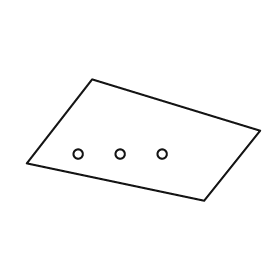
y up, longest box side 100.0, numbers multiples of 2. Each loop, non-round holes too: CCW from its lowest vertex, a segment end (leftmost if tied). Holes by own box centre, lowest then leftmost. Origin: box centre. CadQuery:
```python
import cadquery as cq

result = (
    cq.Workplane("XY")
    .moveTo(26.0, -26.0)
    .lineTo(50.0, 4.0)
    .lineTo(-22.0, 26.0)
    .lineTo(-50.0, -10.0)
    .close()
    .moveTo(-28.0, -6.0)
    .circle(2.0)
    .moveTo(-10.0, -6.0)
    .circle(2.0)
    .moveTo(8.0, -6.0)
    .circle(2.0)
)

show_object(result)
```